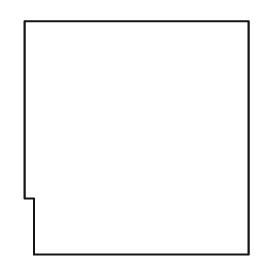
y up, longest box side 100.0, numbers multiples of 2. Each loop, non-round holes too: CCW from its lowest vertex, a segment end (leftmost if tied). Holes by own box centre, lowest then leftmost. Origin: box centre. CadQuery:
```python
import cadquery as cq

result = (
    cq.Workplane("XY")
    .moveTo(-44.0, -50.0)
    .lineTo(48.0, -50.0)
    .lineTo(48.0, 50.0)
    .lineTo(-48.0, 50.0)
    .lineTo(-48.0, -26.0)
    .lineTo(-44.0, -26.0)
    .close()
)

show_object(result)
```